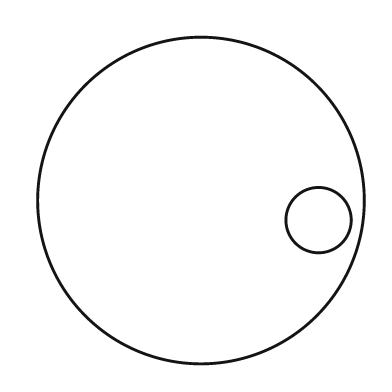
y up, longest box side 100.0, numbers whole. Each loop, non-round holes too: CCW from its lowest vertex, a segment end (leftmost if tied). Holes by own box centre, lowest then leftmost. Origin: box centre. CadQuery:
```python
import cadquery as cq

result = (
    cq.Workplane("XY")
    .moveTo(0.0, 0.0)
    .circle(50.0)
    .moveTo(36.0, -6.0)
    .circle(10.0)
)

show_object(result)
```